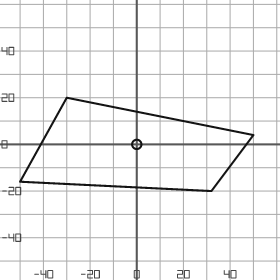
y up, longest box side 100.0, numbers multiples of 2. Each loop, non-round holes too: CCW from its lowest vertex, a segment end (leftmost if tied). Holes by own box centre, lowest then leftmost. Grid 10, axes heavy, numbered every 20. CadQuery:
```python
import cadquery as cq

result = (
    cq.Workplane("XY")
    .moveTo(32.0, -20.0)
    .lineTo(50.0, 4.0)
    .lineTo(-30.0, 20.0)
    .lineTo(-50.0, -16.0)
    .close()
    .moveTo(0.0, 0.0)
    .circle(2.0)
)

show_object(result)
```